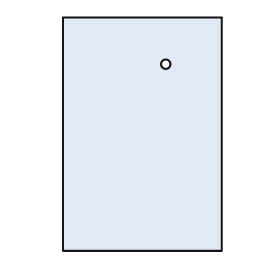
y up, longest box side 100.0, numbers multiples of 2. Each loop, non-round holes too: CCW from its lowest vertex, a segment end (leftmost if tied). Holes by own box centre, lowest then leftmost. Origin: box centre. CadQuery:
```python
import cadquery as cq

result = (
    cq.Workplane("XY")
    .moveTo(-34.0, -50.0)
    .lineTo(34.0, -50.0)
    .lineTo(34.0, 50.0)
    .lineTo(-34.0, 50.0)
    .close()
    .moveTo(10.0, 30.0)
    .circle(2.0)
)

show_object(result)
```